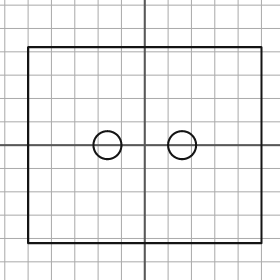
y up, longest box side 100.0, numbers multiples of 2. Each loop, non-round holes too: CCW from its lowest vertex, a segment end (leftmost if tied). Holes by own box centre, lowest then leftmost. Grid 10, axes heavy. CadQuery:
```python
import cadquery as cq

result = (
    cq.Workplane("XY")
    .moveTo(-50.0, -42.0)
    .lineTo(50.0, -42.0)
    .lineTo(50.0, 42.0)
    .lineTo(-50.0, 42.0)
    .close()
    .moveTo(-16.0, 0.0)
    .circle(6.0)
    .moveTo(16.0, 0.0)
    .circle(6.0)
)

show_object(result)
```